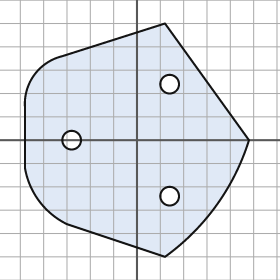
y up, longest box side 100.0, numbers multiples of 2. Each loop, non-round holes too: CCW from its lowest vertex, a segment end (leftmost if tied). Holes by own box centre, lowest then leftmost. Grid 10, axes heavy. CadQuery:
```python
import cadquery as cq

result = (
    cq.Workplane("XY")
    .moveTo(12.0, -50.0)
    .threePointArc((34.0, -28.0), (48.0, 0.0))
    .lineTo(12.0, 50.0)
    .lineTo(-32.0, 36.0)
    .threePointArc((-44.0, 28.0), (-48.0, 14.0))
    .lineTo(-48.0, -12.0)
    .threePointArc((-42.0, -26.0), (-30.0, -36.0))
    .close()
    .moveTo(14.0, -24.0)
    .circle(4.0)
    .moveTo(-28.0, 0.0)
    .circle(4.0)
    .moveTo(14.0, 24.0)
    .circle(4.0)
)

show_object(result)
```